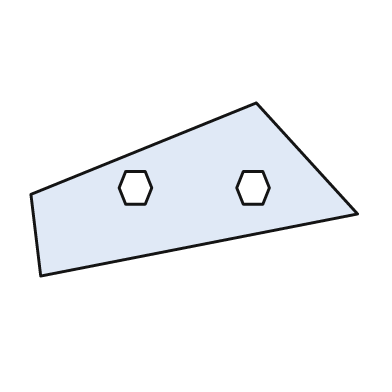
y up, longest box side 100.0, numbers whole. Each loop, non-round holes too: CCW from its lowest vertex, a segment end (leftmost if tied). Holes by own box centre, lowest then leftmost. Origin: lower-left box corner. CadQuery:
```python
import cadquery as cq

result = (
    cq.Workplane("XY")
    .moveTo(3.0, 0.0)
    .lineTo(100.0, 19.0)
    .lineTo(69.0, 53.0)
    .lineTo(0.0, 25.0)
    .close()
    .moveTo(29.0, 22.0)
    .lineTo(35.0, 22.0)
    .lineTo(37.0, 27.0)
    .lineTo(35.0, 32.0)
    .lineTo(29.0, 32.0)
    .lineTo(27.0, 27.0)
    .close()
    .moveTo(65.0, 22.0)
    .lineTo(71.0, 22.0)
    .lineTo(73.0, 27.0)
    .lineTo(71.0, 32.0)
    .lineTo(65.0, 32.0)
    .lineTo(63.0, 27.0)
    .close()
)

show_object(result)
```